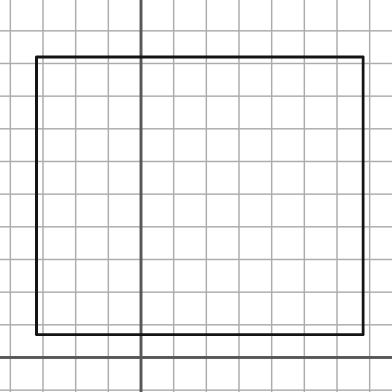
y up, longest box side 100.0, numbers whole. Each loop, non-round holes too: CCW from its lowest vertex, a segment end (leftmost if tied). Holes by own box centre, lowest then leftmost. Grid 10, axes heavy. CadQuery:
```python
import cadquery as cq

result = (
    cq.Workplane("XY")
    .moveTo(-32.0, 7.0)
    .lineTo(68.0, 7.0)
    .lineTo(68.0, 92.0)
    .lineTo(-32.0, 92.0)
    .close()
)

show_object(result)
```